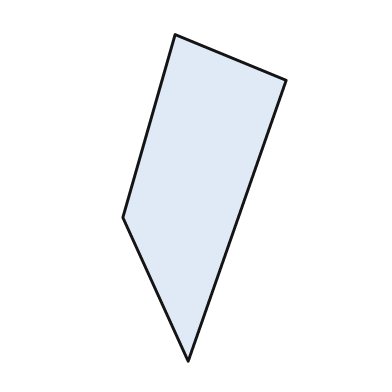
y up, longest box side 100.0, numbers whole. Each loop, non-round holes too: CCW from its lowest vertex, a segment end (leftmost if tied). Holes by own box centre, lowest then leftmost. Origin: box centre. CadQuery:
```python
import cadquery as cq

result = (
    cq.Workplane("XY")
    .moveTo(-5.0, -50.0)
    .lineTo(25.0, 36.0)
    .lineTo(-9.0, 50.0)
    .lineTo(-25.0, -6.0)
    .close()
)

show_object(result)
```